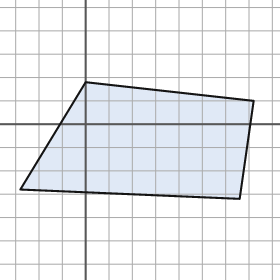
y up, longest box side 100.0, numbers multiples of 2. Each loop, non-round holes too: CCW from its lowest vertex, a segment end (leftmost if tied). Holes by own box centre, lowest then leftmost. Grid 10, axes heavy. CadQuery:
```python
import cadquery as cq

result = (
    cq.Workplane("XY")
    .moveTo(66.0, -32.0)
    .lineTo(72.0, 10.0)
    .lineTo(0.0, 18.0)
    .lineTo(-28.0, -28.0)
    .close()
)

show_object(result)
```